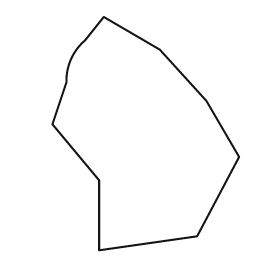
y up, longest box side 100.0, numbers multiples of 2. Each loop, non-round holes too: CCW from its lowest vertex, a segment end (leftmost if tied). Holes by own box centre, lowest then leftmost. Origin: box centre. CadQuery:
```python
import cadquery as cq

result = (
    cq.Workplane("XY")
    .moveTo(-20.0, -50.0)
    .lineTo(22.0, -44.0)
    .lineTo(40.0, -10.0)
    .lineTo(26.0, 14.0)
    .lineTo(6.0, 36.0)
    .lineTo(-18.0, 50.0)
    .lineTo(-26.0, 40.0)
    .threePointArc((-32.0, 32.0), (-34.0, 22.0))
    .lineTo(-40.0, 4.0)
    .lineTo(-20.0, -20.0)
    .close()
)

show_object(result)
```